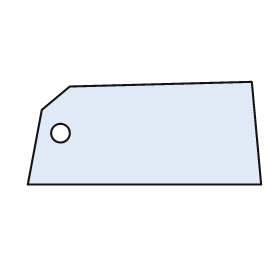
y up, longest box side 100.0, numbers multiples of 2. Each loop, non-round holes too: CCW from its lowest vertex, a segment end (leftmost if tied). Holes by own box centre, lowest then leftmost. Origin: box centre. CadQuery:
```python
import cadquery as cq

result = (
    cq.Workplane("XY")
    .moveTo(-50.0, -22.0)
    .lineTo(50.0, -22.0)
    .lineTo(46.0, 22.0)
    .lineTo(-32.0, 20.0)
    .lineTo(-44.0, 10.0)
    .close()
    .moveTo(-36.0, 0.0)
    .circle(4.0)
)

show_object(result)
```